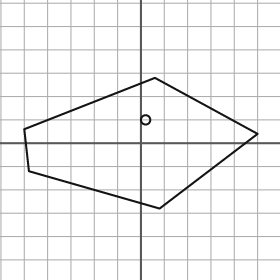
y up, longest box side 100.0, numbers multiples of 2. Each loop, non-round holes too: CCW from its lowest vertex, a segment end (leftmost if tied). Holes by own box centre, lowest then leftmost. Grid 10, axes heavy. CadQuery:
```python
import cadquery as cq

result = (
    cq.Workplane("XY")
    .moveTo(8.0, -28.0)
    .lineTo(50.0, 4.0)
    .lineTo(6.0, 28.0)
    .lineTo(-50.0, 6.0)
    .lineTo(-48.0, -12.0)
    .close()
    .moveTo(2.0, 10.0)
    .circle(2.0)
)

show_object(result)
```